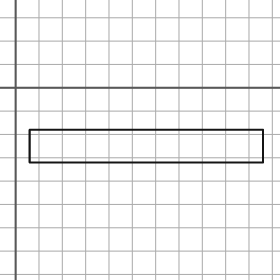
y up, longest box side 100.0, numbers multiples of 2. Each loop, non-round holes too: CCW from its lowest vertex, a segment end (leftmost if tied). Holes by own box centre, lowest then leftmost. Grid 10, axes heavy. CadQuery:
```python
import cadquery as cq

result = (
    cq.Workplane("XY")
    .moveTo(6.0, -32.0)
    .lineTo(106.0, -32.0)
    .lineTo(106.0, -18.0)
    .lineTo(6.0, -18.0)
    .close()
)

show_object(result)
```